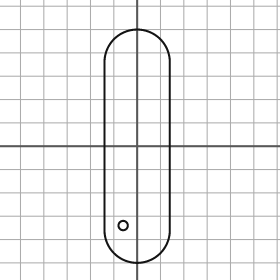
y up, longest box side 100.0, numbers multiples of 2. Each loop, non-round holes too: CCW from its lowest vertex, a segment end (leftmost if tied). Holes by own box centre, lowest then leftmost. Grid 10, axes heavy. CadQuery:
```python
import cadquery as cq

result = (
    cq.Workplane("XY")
    .moveTo(-14.0, -36.0)
    .threePointArc((0.0, -50.0), (14.0, -36.0))
    .lineTo(14.0, 36.0)
    .threePointArc((0.0, 50.0), (-14.0, 36.0))
    .close()
    .moveTo(-6.0, -34.0)
    .circle(2.0)
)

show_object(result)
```